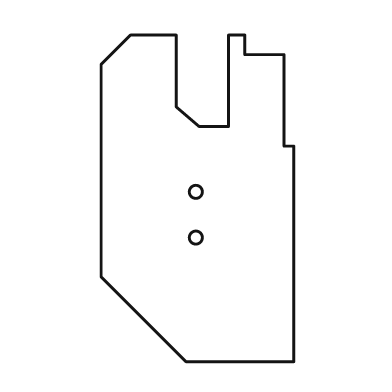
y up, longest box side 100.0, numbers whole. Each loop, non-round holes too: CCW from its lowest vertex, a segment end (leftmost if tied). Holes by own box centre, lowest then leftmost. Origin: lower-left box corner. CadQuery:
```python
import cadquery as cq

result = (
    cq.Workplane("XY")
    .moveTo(26.0, 0.0)
    .lineTo(59.0, 0.0)
    .lineTo(59.0, 66.0)
    .lineTo(56.0, 66.0)
    .lineTo(56.0, 94.0)
    .lineTo(44.0, 94.0)
    .lineTo(44.0, 100.0)
    .lineTo(39.0, 100.0)
    .lineTo(39.0, 72.0)
    .lineTo(30.0, 72.0)
    .lineTo(23.0, 78.0)
    .lineTo(23.0, 100.0)
    .lineTo(9.0, 100.0)
    .lineTo(0.0, 91.0)
    .lineTo(0.0, 26.0)
    .close()
    .moveTo(29.0, 38.0)
    .circle(2.0)
    .moveTo(29.0, 52.0)
    .circle(2.0)
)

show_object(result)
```